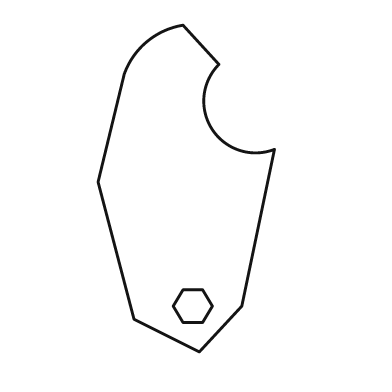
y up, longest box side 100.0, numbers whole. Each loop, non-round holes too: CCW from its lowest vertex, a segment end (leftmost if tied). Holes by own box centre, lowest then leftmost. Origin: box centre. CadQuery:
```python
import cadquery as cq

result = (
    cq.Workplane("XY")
    .moveTo(4.0, -50.0)
    .lineTo(17.0, -36.0)
    .lineTo(27.0, 12.0)
    .threePointArc((8.0, 18.0), (10.0, 38.0))
    .lineTo(-1.0, 50.0)
    .threePointArc((-12.0, 45.0), (-19.0, 35.0))
    .lineTo(-27.0, 2.0)
    .lineTo(-16.0, -40.0)
    .close()
    .moveTo(-1.0, -41.0)
    .lineTo(5.0, -41.0)
    .lineTo(8.0, -36.0)
    .lineTo(5.0, -31.0)
    .lineTo(-1.0, -31.0)
    .lineTo(-4.0, -36.0)
    .close()
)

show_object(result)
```